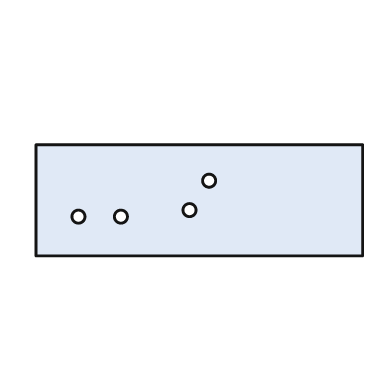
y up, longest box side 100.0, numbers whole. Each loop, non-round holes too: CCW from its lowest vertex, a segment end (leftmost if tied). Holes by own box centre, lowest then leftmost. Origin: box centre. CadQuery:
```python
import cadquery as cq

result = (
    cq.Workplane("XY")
    .moveTo(-50.0, -17.0)
    .lineTo(50.0, -17.0)
    .lineTo(50.0, 17.0)
    .lineTo(-50.0, 17.0)
    .close()
    .moveTo(-37.0, -5.0)
    .circle(2.0)
    .moveTo(-24.0, -5.0)
    .circle(2.0)
    .moveTo(-3.0, -3.0)
    .circle(2.0)
    .moveTo(3.0, 6.0)
    .circle(2.0)
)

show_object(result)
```